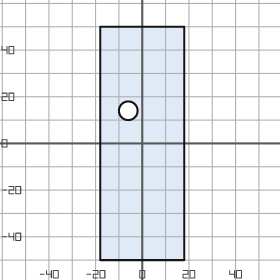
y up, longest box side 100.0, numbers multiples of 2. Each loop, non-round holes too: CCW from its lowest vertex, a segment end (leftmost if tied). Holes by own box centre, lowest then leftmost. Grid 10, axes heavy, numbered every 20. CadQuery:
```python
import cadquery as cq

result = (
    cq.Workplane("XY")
    .moveTo(-18.0, -50.0)
    .lineTo(18.0, -50.0)
    .lineTo(18.0, 50.0)
    .lineTo(-18.0, 50.0)
    .close()
    .moveTo(-6.0, 14.0)
    .circle(4.0)
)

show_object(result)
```